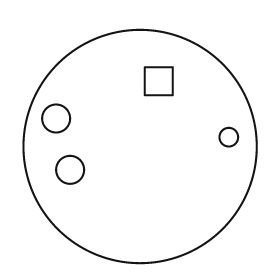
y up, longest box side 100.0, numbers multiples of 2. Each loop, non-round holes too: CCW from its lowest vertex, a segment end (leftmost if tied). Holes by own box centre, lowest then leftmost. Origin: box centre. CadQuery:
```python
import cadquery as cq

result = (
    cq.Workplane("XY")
    .moveTo(0.0, 0.0)
    .circle(50.0)
    .moveTo(-30.0, -10.0)
    .circle(6.0)
    .moveTo(38.0, 4.0)
    .circle(4.0)
    .moveTo(-36.0, 12.0)
    .circle(6.0)
    .moveTo(2.0, 22.0)
    .lineTo(14.0, 22.0)
    .lineTo(14.0, 34.0)
    .lineTo(2.0, 34.0)
    .close()
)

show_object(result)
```